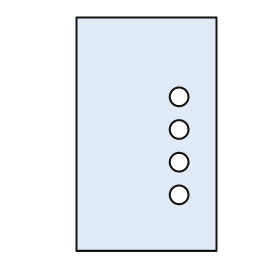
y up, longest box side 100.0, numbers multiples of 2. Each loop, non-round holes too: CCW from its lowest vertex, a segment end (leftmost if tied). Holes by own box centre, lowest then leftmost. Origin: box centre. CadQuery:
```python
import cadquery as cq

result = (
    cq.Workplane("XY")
    .moveTo(-30.0, -50.0)
    .lineTo(30.0, -50.0)
    .lineTo(30.0, 50.0)
    .lineTo(-30.0, 50.0)
    .close()
    .moveTo(14.0, -26.0)
    .circle(4.0)
    .moveTo(14.0, -12.0)
    .circle(4.0)
    .moveTo(14.0, 2.0)
    .circle(4.0)
    .moveTo(14.0, 16.0)
    .circle(4.0)
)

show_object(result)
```